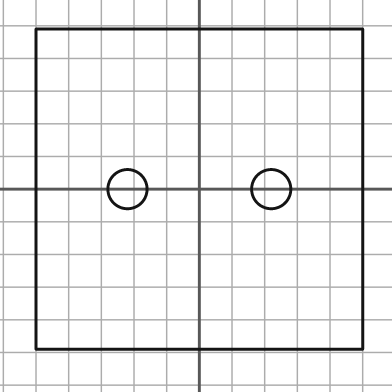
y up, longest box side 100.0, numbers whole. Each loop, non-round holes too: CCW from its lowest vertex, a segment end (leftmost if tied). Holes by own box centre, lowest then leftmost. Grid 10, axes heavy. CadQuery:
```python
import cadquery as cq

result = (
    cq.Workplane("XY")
    .moveTo(-50.0, -49.0)
    .lineTo(50.0, -49.0)
    .lineTo(50.0, 49.0)
    .lineTo(-50.0, 49.0)
    .close()
    .moveTo(-22.0, 0.0)
    .circle(6.0)
    .moveTo(22.0, 0.0)
    .circle(6.0)
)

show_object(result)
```